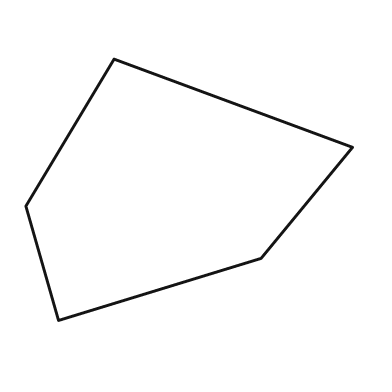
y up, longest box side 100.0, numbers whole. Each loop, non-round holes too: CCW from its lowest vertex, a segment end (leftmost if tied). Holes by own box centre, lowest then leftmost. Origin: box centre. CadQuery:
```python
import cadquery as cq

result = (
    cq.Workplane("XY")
    .moveTo(-40.0, -40.0)
    .lineTo(22.0, -21.0)
    .lineTo(50.0, 13.0)
    .lineTo(-23.0, 40.0)
    .lineTo(-50.0, -5.0)
    .close()
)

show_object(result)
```